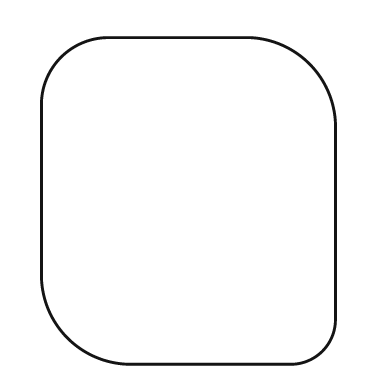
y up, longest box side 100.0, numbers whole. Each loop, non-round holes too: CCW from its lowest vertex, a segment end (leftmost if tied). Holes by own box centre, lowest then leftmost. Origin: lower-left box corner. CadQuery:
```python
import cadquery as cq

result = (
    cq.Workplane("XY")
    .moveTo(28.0, 0.0)
    .lineTo(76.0, 0.0)
    .threePointArc((86.0, 4.0), (90.0, 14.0))
    .lineTo(90.0, 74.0)
    .threePointArc((82.0, 92.0), (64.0, 100.0))
    .lineTo(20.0, 100.0)
    .threePointArc((6.0, 94.0), (0.0, 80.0))
    .lineTo(0.0, 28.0)
    .threePointArc((8.0, 8.0), (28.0, 0.0))
    .close()
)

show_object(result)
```